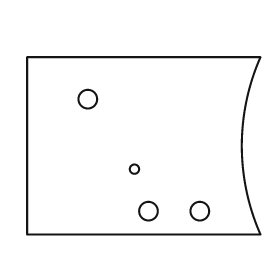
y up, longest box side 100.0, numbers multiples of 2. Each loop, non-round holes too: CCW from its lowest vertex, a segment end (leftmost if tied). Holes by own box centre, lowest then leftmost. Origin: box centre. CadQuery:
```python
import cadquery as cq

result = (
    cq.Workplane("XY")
    .moveTo(-50.0, -38.0)
    .lineTo(50.0, -38.0)
    .threePointArc((42.0, 0.0), (50.0, 38.0))
    .lineTo(-50.0, 38.0)
    .close()
    .moveTo(2.0, -28.0)
    .circle(4.0)
    .moveTo(24.0, -28.0)
    .circle(4.0)
    .moveTo(-4.0, -10.0)
    .circle(2.0)
    .moveTo(-24.0, 20.0)
    .circle(4.0)
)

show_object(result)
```